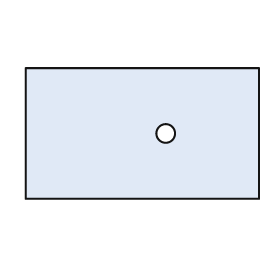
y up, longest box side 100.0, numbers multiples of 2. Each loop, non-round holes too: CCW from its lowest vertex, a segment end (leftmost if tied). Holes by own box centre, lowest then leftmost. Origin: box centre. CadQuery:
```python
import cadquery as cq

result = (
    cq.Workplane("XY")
    .moveTo(-50.0, -28.0)
    .lineTo(50.0, -28.0)
    .lineTo(50.0, 28.0)
    .lineTo(-50.0, 28.0)
    .close()
    .moveTo(10.0, 0.0)
    .circle(4.0)
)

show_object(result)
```